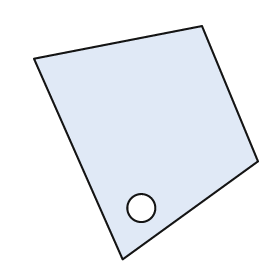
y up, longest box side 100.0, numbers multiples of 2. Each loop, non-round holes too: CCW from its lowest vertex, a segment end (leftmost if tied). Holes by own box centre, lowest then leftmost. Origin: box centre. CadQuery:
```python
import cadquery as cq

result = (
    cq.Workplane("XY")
    .moveTo(-10.0, -50.0)
    .lineTo(48.0, -8.0)
    .lineTo(24.0, 50.0)
    .lineTo(-48.0, 36.0)
    .close()
    .moveTo(-2.0, -28.0)
    .circle(6.0)
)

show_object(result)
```